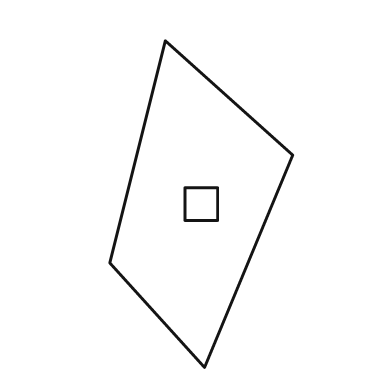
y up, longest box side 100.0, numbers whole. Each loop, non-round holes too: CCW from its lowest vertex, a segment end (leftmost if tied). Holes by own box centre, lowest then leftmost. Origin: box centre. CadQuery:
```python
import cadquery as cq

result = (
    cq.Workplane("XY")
    .moveTo(1.0, -50.0)
    .lineTo(28.0, 15.0)
    .lineTo(-11.0, 50.0)
    .lineTo(-28.0, -18.0)
    .close()
    .moveTo(-5.0, -5.0)
    .lineTo(5.0, -5.0)
    .lineTo(5.0, 5.0)
    .lineTo(-5.0, 5.0)
    .close()
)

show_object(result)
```